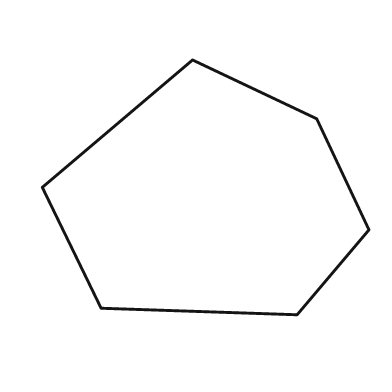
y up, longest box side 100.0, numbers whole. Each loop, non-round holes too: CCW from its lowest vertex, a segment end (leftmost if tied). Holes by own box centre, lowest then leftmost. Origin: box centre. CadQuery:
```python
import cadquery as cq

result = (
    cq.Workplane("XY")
    .moveTo(28.0, -39.0)
    .lineTo(50.0, -13.0)
    .lineTo(34.0, 21.0)
    .lineTo(-4.0, 39.0)
    .lineTo(-50.0, 0.0)
    .lineTo(-32.0, -37.0)
    .close()
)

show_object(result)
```